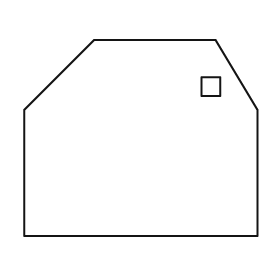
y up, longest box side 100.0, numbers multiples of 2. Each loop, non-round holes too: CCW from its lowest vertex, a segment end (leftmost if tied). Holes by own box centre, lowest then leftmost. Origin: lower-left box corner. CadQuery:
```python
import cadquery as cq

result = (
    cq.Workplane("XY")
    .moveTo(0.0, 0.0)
    .lineTo(100.0, 0.0)
    .lineTo(100.0, 54.0)
    .lineTo(82.0, 84.0)
    .lineTo(30.0, 84.0)
    .lineTo(0.0, 54.0)
    .close()
    .moveTo(76.0, 60.0)
    .lineTo(84.0, 60.0)
    .lineTo(84.0, 68.0)
    .lineTo(76.0, 68.0)
    .close()
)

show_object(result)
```